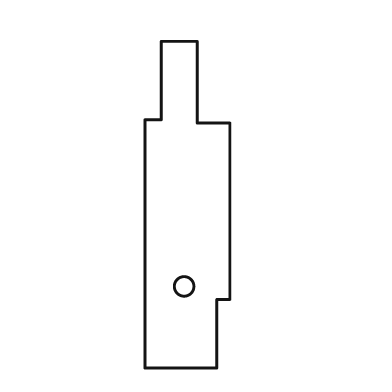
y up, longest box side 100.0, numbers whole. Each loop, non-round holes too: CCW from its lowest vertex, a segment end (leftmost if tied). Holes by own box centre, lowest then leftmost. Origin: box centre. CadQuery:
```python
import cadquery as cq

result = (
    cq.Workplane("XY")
    .moveTo(-13.0, -50.0)
    .lineTo(9.0, -50.0)
    .lineTo(9.0, -29.0)
    .lineTo(13.0, -29.0)
    .lineTo(13.0, 25.0)
    .lineTo(3.0, 25.0)
    .lineTo(3.0, 50.0)
    .lineTo(-8.0, 50.0)
    .lineTo(-8.0, 26.0)
    .lineTo(-13.0, 26.0)
    .close()
    .moveTo(-1.0, -25.0)
    .circle(3.0)
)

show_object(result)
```